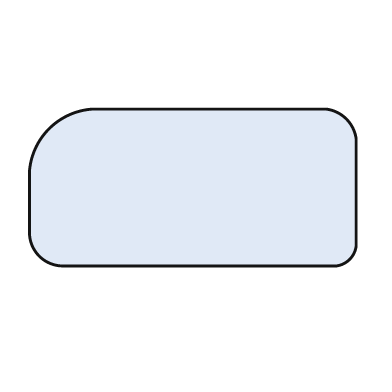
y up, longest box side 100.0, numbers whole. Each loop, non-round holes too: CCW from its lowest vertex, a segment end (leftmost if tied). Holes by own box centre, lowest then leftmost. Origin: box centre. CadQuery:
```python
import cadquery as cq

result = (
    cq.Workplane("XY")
    .moveTo(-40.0, -24.0)
    .lineTo(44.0, -24.0)
    .threePointArc((48.0, -22.0), (50.0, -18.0))
    .lineTo(50.0, 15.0)
    .threePointArc((47.0, 21.0), (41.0, 24.0))
    .lineTo(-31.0, 24.0)
    .threePointArc((-44.0, 18.0), (-50.0, 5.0))
    .lineTo(-50.0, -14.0)
    .threePointArc((-47.0, -21.0), (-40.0, -24.0))
    .close()
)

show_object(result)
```